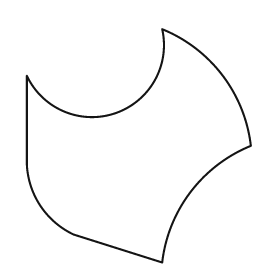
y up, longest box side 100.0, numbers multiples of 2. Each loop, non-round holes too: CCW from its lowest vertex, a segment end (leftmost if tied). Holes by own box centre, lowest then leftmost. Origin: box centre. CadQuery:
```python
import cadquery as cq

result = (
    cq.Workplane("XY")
    .moveTo(10.0, -50.0)
    .threePointArc((22.0, -20.0), (48.0, 0.0))
    .threePointArc((36.0, 30.0), (10.0, 50.0))
    .threePointArc((-10.0, 14.0), (-48.0, 30.0))
    .lineTo(-48.0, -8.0)
    .threePointArc((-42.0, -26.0), (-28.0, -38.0))
    .close()
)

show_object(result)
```